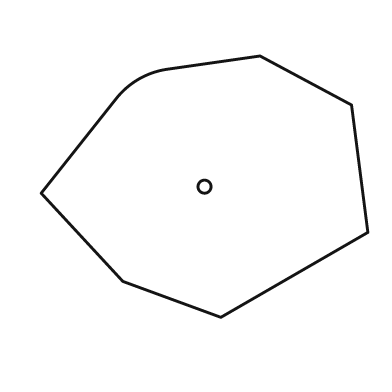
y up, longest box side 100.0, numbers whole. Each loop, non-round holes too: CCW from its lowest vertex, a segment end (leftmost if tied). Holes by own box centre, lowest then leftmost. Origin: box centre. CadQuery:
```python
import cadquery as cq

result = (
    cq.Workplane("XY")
    .moveTo(5.0, -40.0)
    .lineTo(50.0, -14.0)
    .lineTo(45.0, 25.0)
    .lineTo(17.0, 40.0)
    .lineTo(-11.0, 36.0)
    .threePointArc((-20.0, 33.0), (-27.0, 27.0))
    .lineTo(-50.0, -2.0)
    .lineTo(-25.0, -29.0)
    .close()
    .moveTo(0.0, 0.0)
    .circle(2.0)
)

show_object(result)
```